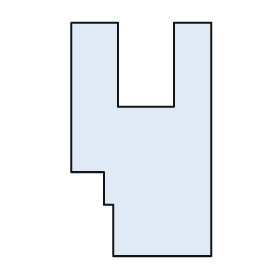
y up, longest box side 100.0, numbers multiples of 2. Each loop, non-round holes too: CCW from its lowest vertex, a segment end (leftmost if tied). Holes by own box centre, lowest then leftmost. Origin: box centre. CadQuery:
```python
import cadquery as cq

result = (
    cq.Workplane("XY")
    .moveTo(-12.0, -50.0)
    .lineTo(30.0, -50.0)
    .lineTo(30.0, 50.0)
    .lineTo(14.0, 50.0)
    .lineTo(14.0, 14.0)
    .lineTo(-10.0, 14.0)
    .lineTo(-10.0, 50.0)
    .lineTo(-30.0, 50.0)
    .lineTo(-30.0, -14.0)
    .lineTo(-16.0, -14.0)
    .lineTo(-16.0, -28.0)
    .lineTo(-12.0, -28.0)
    .close()
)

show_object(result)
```